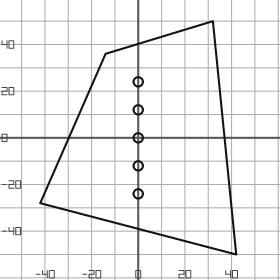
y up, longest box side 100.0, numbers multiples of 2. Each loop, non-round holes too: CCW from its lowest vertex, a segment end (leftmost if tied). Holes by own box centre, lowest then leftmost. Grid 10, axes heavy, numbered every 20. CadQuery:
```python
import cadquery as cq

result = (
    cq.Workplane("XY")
    .moveTo(42.0, -50.0)
    .lineTo(32.0, 50.0)
    .lineTo(-14.0, 36.0)
    .lineTo(-42.0, -28.0)
    .close()
    .moveTo(0.0, -24.0)
    .circle(2.0)
    .moveTo(0.0, -12.0)
    .circle(2.0)
    .moveTo(0.0, 0.0)
    .circle(2.0)
    .moveTo(0.0, 12.0)
    .circle(2.0)
    .moveTo(0.0, 24.0)
    .circle(2.0)
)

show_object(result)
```